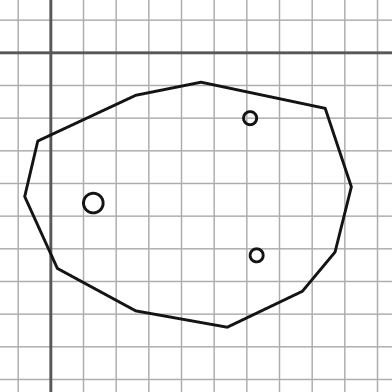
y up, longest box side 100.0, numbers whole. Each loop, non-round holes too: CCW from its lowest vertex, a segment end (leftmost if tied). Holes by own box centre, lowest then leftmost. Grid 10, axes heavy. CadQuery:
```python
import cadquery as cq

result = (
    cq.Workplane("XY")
    .moveTo(54.0, -84.0)
    .lineTo(77.0, -73.0)
    .lineTo(87.0, -61.0)
    .lineTo(92.0, -41.0)
    .lineTo(84.0, -17.0)
    .lineTo(46.0, -9.0)
    .lineTo(26.0, -13.0)
    .lineTo(-4.0, -27.0)
    .lineTo(-8.0, -44.0)
    .lineTo(2.0, -66.0)
    .lineTo(26.0, -79.0)
    .close()
    .moveTo(63.0, -62.0)
    .circle(2.0)
    .moveTo(13.0, -46.0)
    .circle(3.0)
    .moveTo(61.0, -20.0)
    .circle(2.0)
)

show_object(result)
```